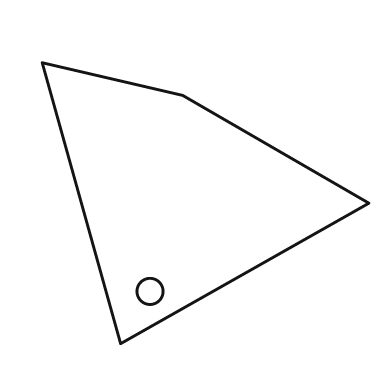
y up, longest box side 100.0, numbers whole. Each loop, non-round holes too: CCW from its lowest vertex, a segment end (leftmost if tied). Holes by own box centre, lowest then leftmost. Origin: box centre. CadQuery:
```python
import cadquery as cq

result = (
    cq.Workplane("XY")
    .moveTo(-26.0, -43.0)
    .lineTo(50.0, 0.0)
    .lineTo(-7.0, 33.0)
    .lineTo(-50.0, 43.0)
    .close()
    .moveTo(-17.0, -27.0)
    .circle(4.0)
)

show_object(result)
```